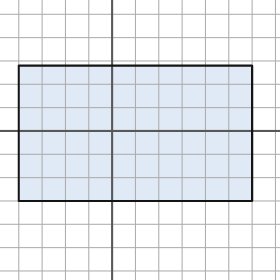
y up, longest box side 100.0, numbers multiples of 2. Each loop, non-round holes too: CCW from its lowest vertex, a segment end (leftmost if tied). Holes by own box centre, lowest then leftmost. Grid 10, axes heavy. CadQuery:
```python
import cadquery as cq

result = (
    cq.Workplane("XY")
    .moveTo(-40.0, -30.0)
    .lineTo(60.0, -30.0)
    .lineTo(60.0, 28.0)
    .lineTo(-40.0, 28.0)
    .close()
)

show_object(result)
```